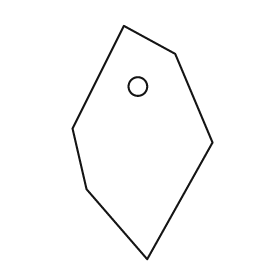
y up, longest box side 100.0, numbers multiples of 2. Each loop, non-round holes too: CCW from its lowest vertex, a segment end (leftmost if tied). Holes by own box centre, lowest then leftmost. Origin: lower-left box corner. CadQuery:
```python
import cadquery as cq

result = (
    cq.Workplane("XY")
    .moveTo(32.0, 0.0)
    .lineTo(60.0, 50.0)
    .lineTo(44.0, 88.0)
    .lineTo(22.0, 100.0)
    .lineTo(0.0, 56.0)
    .lineTo(6.0, 30.0)
    .close()
    .moveTo(28.0, 74.0)
    .circle(4.0)
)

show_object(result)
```